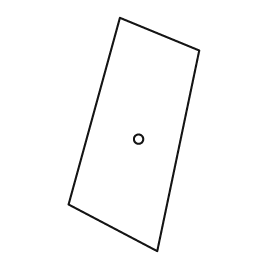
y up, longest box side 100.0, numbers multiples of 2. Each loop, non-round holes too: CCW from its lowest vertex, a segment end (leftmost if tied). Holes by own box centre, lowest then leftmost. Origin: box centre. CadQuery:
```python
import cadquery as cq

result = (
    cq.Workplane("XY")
    .moveTo(10.0, -50.0)
    .lineTo(28.0, 36.0)
    .lineTo(-6.0, 50.0)
    .lineTo(-28.0, -30.0)
    .close()
    .moveTo(2.0, -2.0)
    .circle(2.0)
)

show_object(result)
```